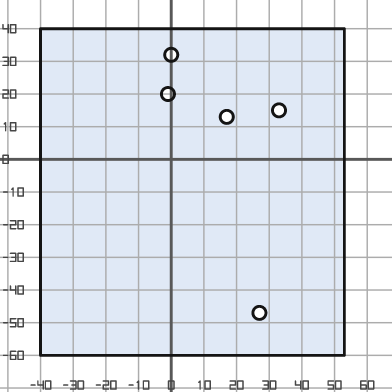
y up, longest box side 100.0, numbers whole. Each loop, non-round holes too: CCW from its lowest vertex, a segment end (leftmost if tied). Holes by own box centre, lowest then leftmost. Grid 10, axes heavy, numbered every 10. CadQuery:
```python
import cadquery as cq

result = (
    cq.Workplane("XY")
    .moveTo(-40.0, -60.0)
    .lineTo(53.0, -60.0)
    .lineTo(53.0, 40.0)
    .lineTo(-40.0, 40.0)
    .close()
    .moveTo(27.0, -47.0)
    .circle(2.0)
    .moveTo(17.0, 13.0)
    .circle(2.0)
    .moveTo(33.0, 15.0)
    .circle(2.0)
    .moveTo(-1.0, 20.0)
    .circle(2.0)
    .moveTo(0.0, 32.0)
    .circle(2.0)
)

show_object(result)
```